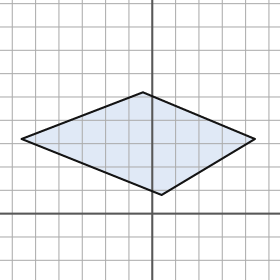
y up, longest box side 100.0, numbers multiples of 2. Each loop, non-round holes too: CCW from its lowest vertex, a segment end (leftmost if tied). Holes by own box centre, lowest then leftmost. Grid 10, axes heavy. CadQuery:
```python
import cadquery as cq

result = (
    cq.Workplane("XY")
    .moveTo(4.0, 8.0)
    .lineTo(44.0, 32.0)
    .lineTo(-4.0, 52.0)
    .lineTo(-56.0, 32.0)
    .close()
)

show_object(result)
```